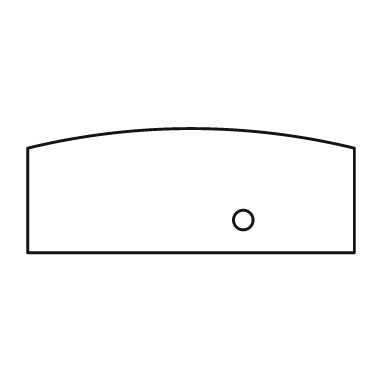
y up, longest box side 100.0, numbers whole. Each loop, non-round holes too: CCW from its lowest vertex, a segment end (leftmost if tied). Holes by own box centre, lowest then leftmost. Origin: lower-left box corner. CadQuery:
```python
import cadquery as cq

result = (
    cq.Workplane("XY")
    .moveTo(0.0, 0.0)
    .lineTo(100.0, 0.0)
    .lineTo(100.0, 32.0)
    .threePointArc((50.0, 38.0), (0.0, 32.0))
    .close()
    .moveTo(66.0, 10.0)
    .circle(3.0)
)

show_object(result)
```